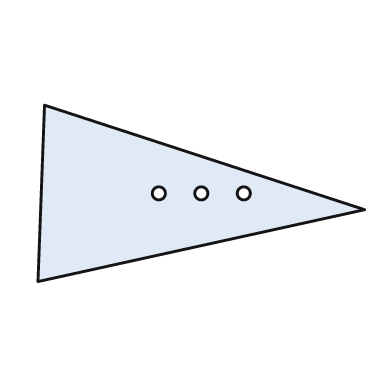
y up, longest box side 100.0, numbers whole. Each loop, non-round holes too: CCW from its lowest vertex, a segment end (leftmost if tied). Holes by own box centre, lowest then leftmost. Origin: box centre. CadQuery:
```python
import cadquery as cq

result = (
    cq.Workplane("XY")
    .moveTo(-50.0, -27.0)
    .lineTo(50.0, -5.0)
    .lineTo(-48.0, 27.0)
    .close()
    .moveTo(-13.0, 0.0)
    .circle(2.0)
    .moveTo(0.0, 0.0)
    .circle(2.0)
    .moveTo(13.0, 0.0)
    .circle(2.0)
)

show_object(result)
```